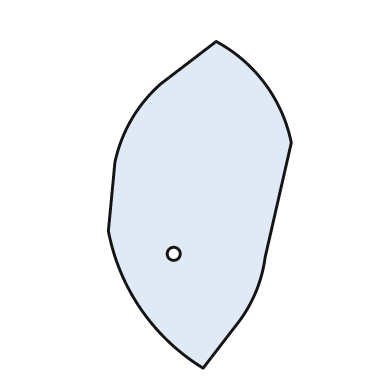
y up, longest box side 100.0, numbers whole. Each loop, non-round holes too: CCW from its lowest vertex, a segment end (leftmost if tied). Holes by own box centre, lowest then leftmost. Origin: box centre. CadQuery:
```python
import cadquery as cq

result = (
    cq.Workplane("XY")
    .moveTo(1.0, -50.0)
    .lineTo(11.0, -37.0)
    .threePointArc((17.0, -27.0), (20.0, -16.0))
    .lineTo(28.0, 19.0)
    .threePointArc((20.0, 37.0), (5.0, 50.0))
    .lineTo(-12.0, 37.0)
    .threePointArc((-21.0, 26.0), (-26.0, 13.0))
    .lineTo(-28.0, -8.0)
    .threePointArc((-18.0, -32.0), (1.0, -50.0))
    .close()
    .moveTo(-8.0, -15.0)
    .circle(2.0)
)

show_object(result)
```